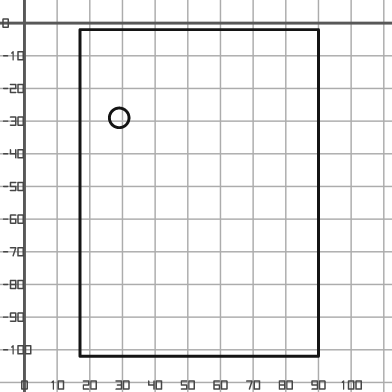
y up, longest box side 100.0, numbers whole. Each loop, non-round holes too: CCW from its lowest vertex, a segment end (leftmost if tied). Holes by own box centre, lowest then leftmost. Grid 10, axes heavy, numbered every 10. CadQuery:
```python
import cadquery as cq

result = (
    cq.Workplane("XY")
    .moveTo(17.0, -102.0)
    .lineTo(90.0, -102.0)
    .lineTo(90.0, -2.0)
    .lineTo(17.0, -2.0)
    .close()
    .moveTo(29.0, -29.0)
    .circle(3.0)
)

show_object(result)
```